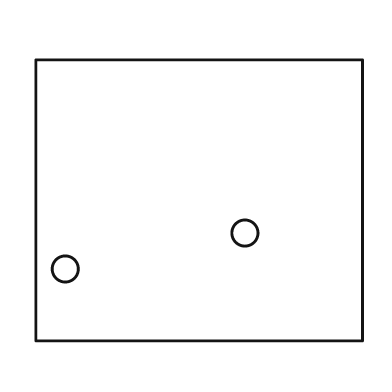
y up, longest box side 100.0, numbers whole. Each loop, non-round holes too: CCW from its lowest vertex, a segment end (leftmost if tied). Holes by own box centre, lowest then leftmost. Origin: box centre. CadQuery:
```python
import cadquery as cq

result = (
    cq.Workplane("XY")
    .moveTo(-50.0, -43.0)
    .lineTo(50.0, -43.0)
    .lineTo(50.0, 43.0)
    .lineTo(-50.0, 43.0)
    .close()
    .moveTo(-41.0, -21.0)
    .circle(4.0)
    .moveTo(14.0, -10.0)
    .circle(4.0)
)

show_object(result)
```